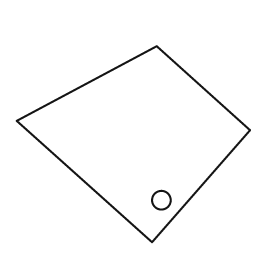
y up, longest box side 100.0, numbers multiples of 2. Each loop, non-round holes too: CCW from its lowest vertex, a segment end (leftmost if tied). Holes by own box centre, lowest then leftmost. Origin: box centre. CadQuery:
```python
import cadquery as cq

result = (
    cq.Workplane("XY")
    .moveTo(8.0, -42.0)
    .lineTo(50.0, 6.0)
    .lineTo(10.0, 42.0)
    .lineTo(-50.0, 10.0)
    .close()
    .moveTo(12.0, -24.0)
    .circle(4.0)
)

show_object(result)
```